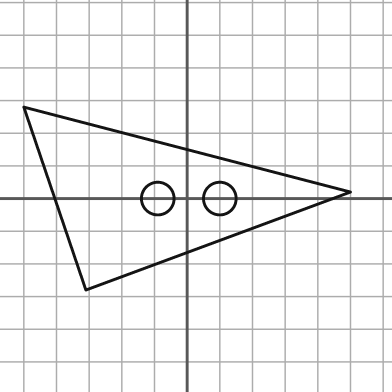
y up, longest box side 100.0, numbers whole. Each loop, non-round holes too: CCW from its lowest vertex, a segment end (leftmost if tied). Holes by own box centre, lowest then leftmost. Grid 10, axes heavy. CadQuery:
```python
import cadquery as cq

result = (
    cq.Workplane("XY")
    .moveTo(-31.0, -28.0)
    .lineTo(50.0, 2.0)
    .lineTo(-50.0, 28.0)
    .close()
    .moveTo(-9.0, 0.0)
    .circle(5.0)
    .moveTo(10.0, 0.0)
    .circle(5.0)
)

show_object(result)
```